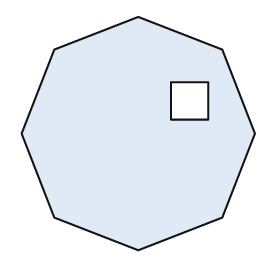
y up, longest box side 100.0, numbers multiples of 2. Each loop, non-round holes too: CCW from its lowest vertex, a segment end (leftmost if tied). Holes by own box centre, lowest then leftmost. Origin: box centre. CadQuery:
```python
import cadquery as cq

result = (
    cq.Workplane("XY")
    .moveTo(0.0, -50.0)
    .lineTo(36.0, -36.0)
    .lineTo(50.0, 0.0)
    .lineTo(36.0, 36.0)
    .lineTo(0.0, 50.0)
    .lineTo(-36.0, 36.0)
    .lineTo(-50.0, 0.0)
    .lineTo(-36.0, -36.0)
    .close()
    .moveTo(14.0, 6.0)
    .lineTo(30.0, 6.0)
    .lineTo(30.0, 22.0)
    .lineTo(14.0, 22.0)
    .close()
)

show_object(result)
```